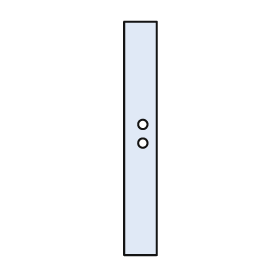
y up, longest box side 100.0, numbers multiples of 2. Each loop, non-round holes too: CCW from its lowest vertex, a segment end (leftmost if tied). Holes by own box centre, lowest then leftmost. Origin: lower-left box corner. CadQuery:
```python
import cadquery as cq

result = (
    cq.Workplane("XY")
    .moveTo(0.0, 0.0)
    .lineTo(14.0, 0.0)
    .lineTo(14.0, 100.0)
    .lineTo(0.0, 100.0)
    .close()
    .moveTo(8.0, 48.0)
    .circle(2.0)
    .moveTo(8.0, 56.0)
    .circle(2.0)
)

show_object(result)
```